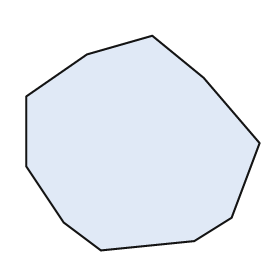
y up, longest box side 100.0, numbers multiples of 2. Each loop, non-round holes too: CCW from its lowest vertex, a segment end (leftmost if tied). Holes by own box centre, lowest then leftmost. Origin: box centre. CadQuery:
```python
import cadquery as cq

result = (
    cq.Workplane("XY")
    .moveTo(-18.0, -46.0)
    .lineTo(22.0, -42.0)
    .lineTo(38.0, -32.0)
    .lineTo(50.0, 0.0)
    .lineTo(26.0, 28.0)
    .lineTo(4.0, 46.0)
    .lineTo(-24.0, 38.0)
    .lineTo(-50.0, 20.0)
    .lineTo(-50.0, -10.0)
    .lineTo(-34.0, -34.0)
    .close()
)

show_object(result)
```